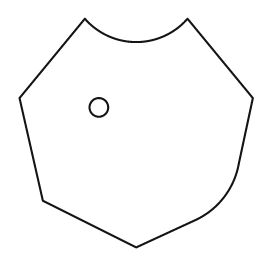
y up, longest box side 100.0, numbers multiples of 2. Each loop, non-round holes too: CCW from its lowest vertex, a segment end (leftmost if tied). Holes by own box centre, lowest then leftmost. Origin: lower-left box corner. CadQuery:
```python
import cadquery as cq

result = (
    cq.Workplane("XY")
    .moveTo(50.0, 0.0)
    .lineTo(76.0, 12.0)
    .threePointArc((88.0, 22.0), (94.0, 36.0))
    .lineTo(100.0, 64.0)
    .lineTo(72.0, 98.0)
    .threePointArc((50.0, 88.0), (28.0, 98.0))
    .lineTo(0.0, 64.0)
    .lineTo(10.0, 20.0)
    .close()
    .moveTo(34.0, 60.0)
    .circle(4.0)
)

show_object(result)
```